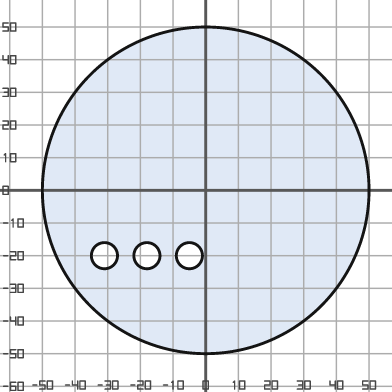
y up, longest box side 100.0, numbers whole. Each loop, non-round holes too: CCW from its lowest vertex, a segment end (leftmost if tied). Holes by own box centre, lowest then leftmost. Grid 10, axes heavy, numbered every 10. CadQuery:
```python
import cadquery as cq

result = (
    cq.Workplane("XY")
    .moveTo(0.0, 0.0)
    .circle(50.0)
    .moveTo(-31.0, -20.0)
    .circle(4.0)
    .moveTo(-18.0, -20.0)
    .circle(4.0)
    .moveTo(-5.0, -20.0)
    .circle(4.0)
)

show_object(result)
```